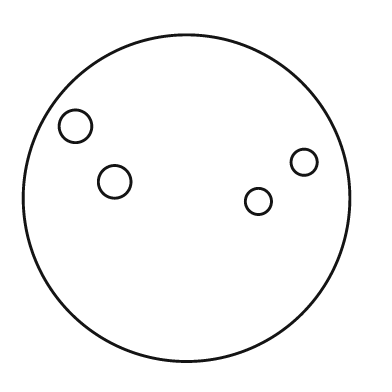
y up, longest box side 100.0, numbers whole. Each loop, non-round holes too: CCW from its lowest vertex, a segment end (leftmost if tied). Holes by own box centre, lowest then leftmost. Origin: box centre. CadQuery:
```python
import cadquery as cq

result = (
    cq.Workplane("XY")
    .moveTo(0.0, 0.0)
    .circle(50.0)
    .moveTo(22.0, -1.0)
    .circle(4.0)
    .moveTo(-22.0, 5.0)
    .circle(5.0)
    .moveTo(36.0, 11.0)
    .circle(4.0)
    .moveTo(-34.0, 22.0)
    .circle(5.0)
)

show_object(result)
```